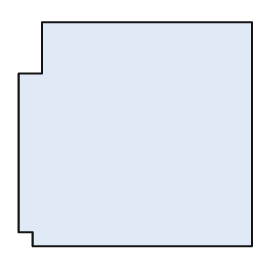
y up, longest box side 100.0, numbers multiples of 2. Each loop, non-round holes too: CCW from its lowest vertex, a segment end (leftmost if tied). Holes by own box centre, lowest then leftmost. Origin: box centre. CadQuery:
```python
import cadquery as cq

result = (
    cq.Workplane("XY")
    .moveTo(-44.0, -48.0)
    .lineTo(50.0, -48.0)
    .lineTo(50.0, 48.0)
    .lineTo(-40.0, 48.0)
    .lineTo(-40.0, 26.0)
    .lineTo(-50.0, 26.0)
    .lineTo(-50.0, -42.0)
    .lineTo(-44.0, -42.0)
    .close()
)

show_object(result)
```